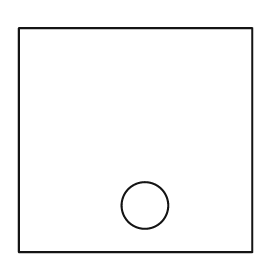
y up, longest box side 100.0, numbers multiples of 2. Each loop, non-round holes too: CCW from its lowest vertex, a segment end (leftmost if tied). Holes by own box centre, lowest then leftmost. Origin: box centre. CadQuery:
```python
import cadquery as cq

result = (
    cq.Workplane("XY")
    .moveTo(-50.0, -48.0)
    .lineTo(50.0, -48.0)
    .lineTo(50.0, 48.0)
    .lineTo(-50.0, 48.0)
    .close()
    .moveTo(4.0, -28.0)
    .circle(10.0)
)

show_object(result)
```